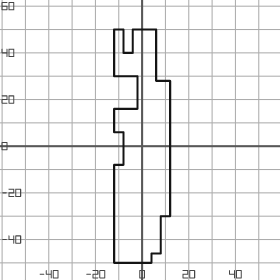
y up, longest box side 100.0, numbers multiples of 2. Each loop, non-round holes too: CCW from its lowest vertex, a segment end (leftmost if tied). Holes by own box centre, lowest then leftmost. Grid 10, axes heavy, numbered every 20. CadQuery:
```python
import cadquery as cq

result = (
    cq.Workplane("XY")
    .moveTo(-12.0, -50.0)
    .lineTo(4.0, -50.0)
    .lineTo(4.0, -46.0)
    .lineTo(8.0, -46.0)
    .lineTo(8.0, -30.0)
    .lineTo(12.0, -30.0)
    .lineTo(12.0, 28.0)
    .lineTo(6.0, 28.0)
    .lineTo(6.0, 50.0)
    .lineTo(-4.0, 50.0)
    .lineTo(-4.0, 40.0)
    .lineTo(-8.0, 40.0)
    .lineTo(-8.0, 50.0)
    .lineTo(-12.0, 50.0)
    .lineTo(-12.0, 30.0)
    .lineTo(-2.0, 30.0)
    .lineTo(-2.0, 16.0)
    .lineTo(-12.0, 16.0)
    .lineTo(-12.0, 6.0)
    .lineTo(-8.0, 6.0)
    .lineTo(-8.0, -8.0)
    .lineTo(-12.0, -8.0)
    .close()
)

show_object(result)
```